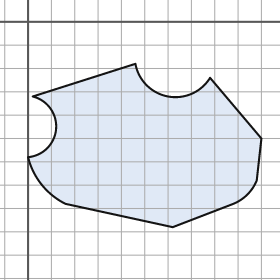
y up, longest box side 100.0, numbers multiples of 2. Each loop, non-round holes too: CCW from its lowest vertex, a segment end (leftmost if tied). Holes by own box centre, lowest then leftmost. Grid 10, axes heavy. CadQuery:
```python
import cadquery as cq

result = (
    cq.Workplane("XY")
    .moveTo(62.0, -88.0)
    .lineTo(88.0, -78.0)
    .threePointArc((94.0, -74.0), (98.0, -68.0))
    .lineTo(100.0, -50.0)
    .lineTo(78.0, -24.0)
    .threePointArc((60.0, -32.0), (46.0, -18.0))
    .lineTo(2.0, -32.0)
    .threePointArc((12.0, -46.0), (0.0, -58.0))
    .threePointArc((6.0, -70.0), (16.0, -78.0))
    .close()
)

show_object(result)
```